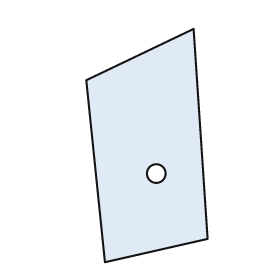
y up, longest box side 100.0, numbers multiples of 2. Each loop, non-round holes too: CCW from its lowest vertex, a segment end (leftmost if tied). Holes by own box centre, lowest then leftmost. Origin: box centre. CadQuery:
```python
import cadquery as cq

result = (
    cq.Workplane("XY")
    .moveTo(-18.0, -50.0)
    .lineTo(26.0, -40.0)
    .lineTo(20.0, 50.0)
    .lineTo(-26.0, 28.0)
    .close()
    .moveTo(4.0, -12.0)
    .circle(4.0)
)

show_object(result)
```